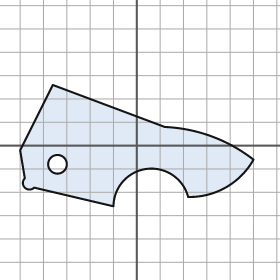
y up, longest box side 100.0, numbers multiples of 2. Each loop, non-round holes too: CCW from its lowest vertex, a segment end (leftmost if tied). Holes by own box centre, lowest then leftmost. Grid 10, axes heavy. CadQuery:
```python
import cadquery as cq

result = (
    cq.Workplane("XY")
    .moveTo(-10.0, -26.0)
    .threePointArc((4.0, -10.0), (22.0, -22.0))
    .threePointArc((38.0, -18.0), (50.0, -6.0))
    .threePointArc((32.0, 4.0), (12.0, 8.0))
    .lineTo(-36.0, 26.0)
    .lineTo(-50.0, -2.0)
    .lineTo(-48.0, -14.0)
    .threePointArc((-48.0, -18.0), (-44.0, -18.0))
    .close()
    .moveTo(-34.0, -8.0)
    .circle(4.0)
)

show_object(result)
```